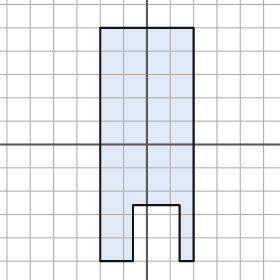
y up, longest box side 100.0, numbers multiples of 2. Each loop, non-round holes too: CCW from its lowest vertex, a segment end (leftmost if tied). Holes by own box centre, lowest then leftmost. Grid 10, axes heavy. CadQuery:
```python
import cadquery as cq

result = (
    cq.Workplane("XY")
    .moveTo(-20.0, -50.0)
    .lineTo(-6.0, -50.0)
    .lineTo(-6.0, -26.0)
    .lineTo(14.0, -26.0)
    .lineTo(14.0, -50.0)
    .lineTo(20.0, -50.0)
    .lineTo(20.0, 50.0)
    .lineTo(-20.0, 50.0)
    .close()
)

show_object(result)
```